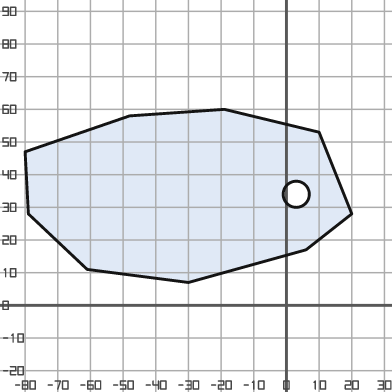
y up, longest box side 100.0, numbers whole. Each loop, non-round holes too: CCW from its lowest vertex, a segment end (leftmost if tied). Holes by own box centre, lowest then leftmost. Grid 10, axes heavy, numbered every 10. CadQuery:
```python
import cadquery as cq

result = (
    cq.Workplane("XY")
    .moveTo(-30.0, 7.0)
    .lineTo(6.0, 17.0)
    .lineTo(20.0, 28.0)
    .lineTo(10.0, 53.0)
    .lineTo(-19.0, 60.0)
    .lineTo(-48.0, 58.0)
    .lineTo(-80.0, 47.0)
    .lineTo(-79.0, 28.0)
    .lineTo(-61.0, 11.0)
    .close()
    .moveTo(3.0, 34.0)
    .circle(4.0)
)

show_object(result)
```